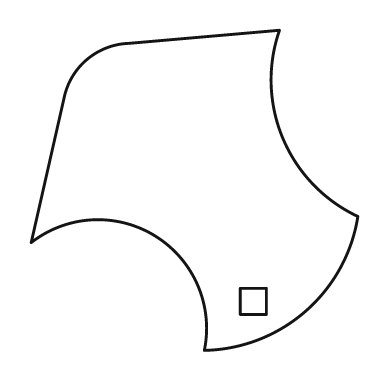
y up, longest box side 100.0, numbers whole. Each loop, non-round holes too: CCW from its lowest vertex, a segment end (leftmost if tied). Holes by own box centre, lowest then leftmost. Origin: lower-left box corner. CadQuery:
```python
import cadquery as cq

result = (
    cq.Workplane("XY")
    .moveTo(53.0, 0.0)
    .threePointArc((84.0, 12.0), (100.0, 41.0))
    .threePointArc((77.0, 65.0), (76.0, 98.0))
    .lineTo(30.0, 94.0)
    .threePointArc((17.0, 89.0), (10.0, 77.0))
    .lineTo(0.0, 33.0)
    .threePointArc((38.0, 35.0), (53.0, 0.0))
    .close()
    .moveTo(64.0, 11.0)
    .lineTo(72.0, 11.0)
    .lineTo(72.0, 19.0)
    .lineTo(64.0, 19.0)
    .close()
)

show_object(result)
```